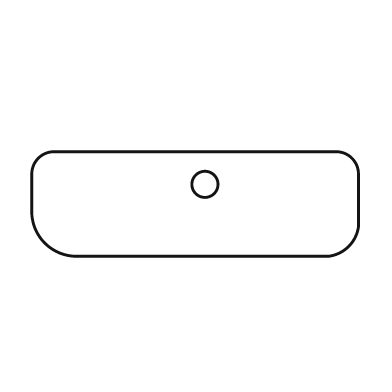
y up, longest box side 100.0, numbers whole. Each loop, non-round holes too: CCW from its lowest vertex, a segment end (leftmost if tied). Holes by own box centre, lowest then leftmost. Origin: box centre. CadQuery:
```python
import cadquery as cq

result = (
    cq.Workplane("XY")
    .moveTo(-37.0, -16.0)
    .lineTo(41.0, -16.0)
    .threePointArc((47.0, -13.0), (50.0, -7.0))
    .lineTo(50.0, 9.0)
    .threePointArc((48.0, 14.0), (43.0, 16.0))
    .lineTo(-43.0, 16.0)
    .threePointArc((-48.0, 14.0), (-50.0, 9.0))
    .lineTo(-50.0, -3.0)
    .threePointArc((-46.0, -12.0), (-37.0, -16.0))
    .close()
    .moveTo(3.0, 6.0)
    .circle(4.0)
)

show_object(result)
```